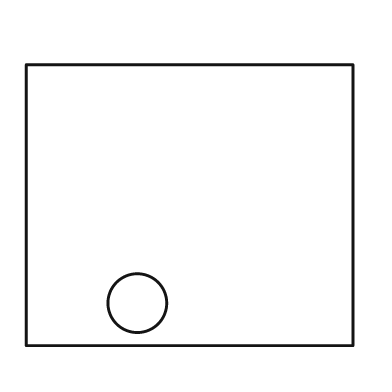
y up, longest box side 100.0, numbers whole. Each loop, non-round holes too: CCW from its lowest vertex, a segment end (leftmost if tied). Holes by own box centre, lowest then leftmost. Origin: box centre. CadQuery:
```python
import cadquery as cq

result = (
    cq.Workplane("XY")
    .moveTo(-50.0, -43.0)
    .lineTo(50.0, -43.0)
    .lineTo(50.0, 43.0)
    .lineTo(-50.0, 43.0)
    .close()
    .moveTo(-16.0, -30.0)
    .circle(9.0)
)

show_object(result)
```